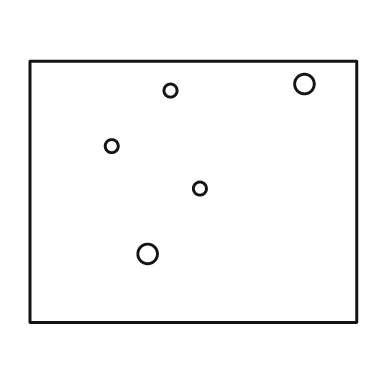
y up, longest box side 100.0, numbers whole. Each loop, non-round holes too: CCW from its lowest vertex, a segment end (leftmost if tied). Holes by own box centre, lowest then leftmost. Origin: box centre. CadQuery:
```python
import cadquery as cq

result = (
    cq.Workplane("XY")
    .moveTo(-50.0, -40.0)
    .lineTo(50.0, -40.0)
    .lineTo(50.0, 40.0)
    .lineTo(-50.0, 40.0)
    .close()
    .moveTo(-14.0, -19.0)
    .circle(3.0)
    .moveTo(2.0, 1.0)
    .circle(2.0)
    .moveTo(-25.0, 14.0)
    .circle(2.0)
    .moveTo(-7.0, 31.0)
    .circle(2.0)
    .moveTo(34.0, 33.0)
    .circle(3.0)
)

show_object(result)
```